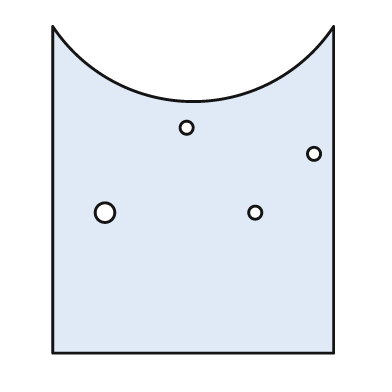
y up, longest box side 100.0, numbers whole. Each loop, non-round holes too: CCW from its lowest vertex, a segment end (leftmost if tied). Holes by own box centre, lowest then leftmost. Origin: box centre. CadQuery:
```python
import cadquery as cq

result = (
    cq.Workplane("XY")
    .moveTo(-43.0, -50.0)
    .lineTo(43.0, -50.0)
    .lineTo(43.0, 50.0)
    .threePointArc((0.0, 27.0), (-43.0, 50.0))
    .close()
    .moveTo(-27.0, -7.0)
    .circle(3.0)
    .moveTo(19.0, -7.0)
    .circle(2.0)
    .moveTo(37.0, 11.0)
    .circle(2.0)
    .moveTo(-2.0, 19.0)
    .circle(2.0)
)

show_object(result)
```